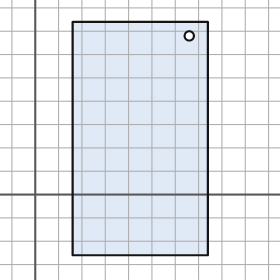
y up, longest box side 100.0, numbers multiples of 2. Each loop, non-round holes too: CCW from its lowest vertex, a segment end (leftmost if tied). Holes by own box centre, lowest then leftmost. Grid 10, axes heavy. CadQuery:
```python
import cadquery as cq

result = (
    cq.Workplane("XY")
    .moveTo(16.0, -26.0)
    .lineTo(74.0, -26.0)
    .lineTo(74.0, 74.0)
    .lineTo(16.0, 74.0)
    .close()
    .moveTo(66.0, 68.0)
    .circle(2.0)
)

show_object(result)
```